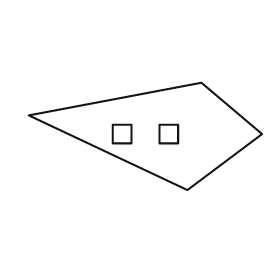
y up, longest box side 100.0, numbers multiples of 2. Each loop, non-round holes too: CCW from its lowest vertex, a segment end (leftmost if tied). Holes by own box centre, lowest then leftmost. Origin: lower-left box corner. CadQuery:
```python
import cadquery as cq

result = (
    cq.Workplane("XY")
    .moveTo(68.0, 0.0)
    .lineTo(100.0, 24.0)
    .lineTo(74.0, 46.0)
    .lineTo(0.0, 32.0)
    .close()
    .moveTo(36.0, 20.0)
    .lineTo(44.0, 20.0)
    .lineTo(44.0, 28.0)
    .lineTo(36.0, 28.0)
    .close()
    .moveTo(56.0, 20.0)
    .lineTo(64.0, 20.0)
    .lineTo(64.0, 28.0)
    .lineTo(56.0, 28.0)
    .close()
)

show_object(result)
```